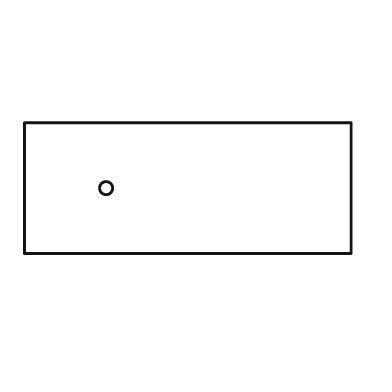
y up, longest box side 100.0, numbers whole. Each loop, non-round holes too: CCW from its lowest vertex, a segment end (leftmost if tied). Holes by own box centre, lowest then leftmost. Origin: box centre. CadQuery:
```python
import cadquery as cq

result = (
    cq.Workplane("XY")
    .moveTo(-50.0, -20.0)
    .lineTo(50.0, -20.0)
    .lineTo(50.0, 20.0)
    .lineTo(-50.0, 20.0)
    .close()
    .moveTo(-25.0, 0.0)
    .circle(2.0)
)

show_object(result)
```